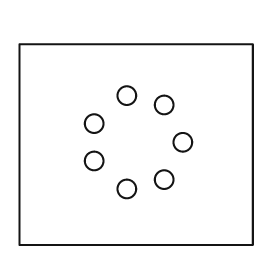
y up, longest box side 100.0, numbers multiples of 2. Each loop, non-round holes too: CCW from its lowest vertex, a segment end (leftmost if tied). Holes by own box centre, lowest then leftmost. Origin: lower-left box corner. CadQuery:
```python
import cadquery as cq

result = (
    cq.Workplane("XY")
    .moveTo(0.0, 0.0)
    .lineTo(100.0, 0.0)
    .lineTo(100.0, 86.0)
    .lineTo(0.0, 86.0)
    .close()
    .moveTo(46.0, 24.0)
    .circle(4.0)
    .moveTo(62.0, 28.0)
    .circle(4.0)
    .moveTo(32.0, 36.0)
    .circle(4.0)
    .moveTo(70.0, 44.0)
    .circle(4.0)
    .moveTo(32.0, 52.0)
    .circle(4.0)
    .moveTo(62.0, 60.0)
    .circle(4.0)
    .moveTo(46.0, 64.0)
    .circle(4.0)
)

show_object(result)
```